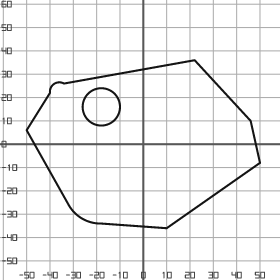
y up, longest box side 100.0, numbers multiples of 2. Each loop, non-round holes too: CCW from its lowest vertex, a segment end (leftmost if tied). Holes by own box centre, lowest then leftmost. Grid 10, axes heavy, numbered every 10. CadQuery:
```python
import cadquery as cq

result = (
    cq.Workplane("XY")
    .moveTo(10.0, -36.0)
    .lineTo(50.0, -8.0)
    .lineTo(46.0, 10.0)
    .lineTo(22.0, 36.0)
    .lineTo(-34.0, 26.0)
    .threePointArc((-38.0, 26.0), (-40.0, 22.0))
    .lineTo(-50.0, 6.0)
    .lineTo(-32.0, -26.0)
    .threePointArc((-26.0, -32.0), (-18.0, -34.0))
    .close()
    .moveTo(-18.0, 16.0)
    .circle(8.0)
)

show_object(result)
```